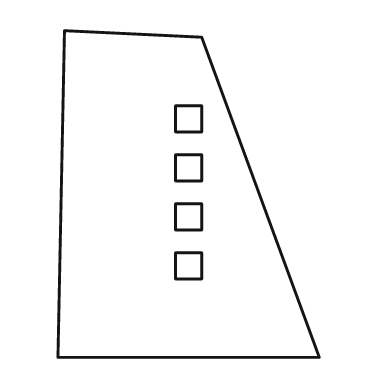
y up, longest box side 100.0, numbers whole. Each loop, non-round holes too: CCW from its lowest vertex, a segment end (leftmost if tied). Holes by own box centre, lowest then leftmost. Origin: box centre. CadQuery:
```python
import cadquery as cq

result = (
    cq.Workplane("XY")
    .moveTo(-40.0, -50.0)
    .lineTo(40.0, -50.0)
    .lineTo(4.0, 48.0)
    .lineTo(-38.0, 50.0)
    .close()
    .moveTo(-4.0, -26.0)
    .lineTo(4.0, -26.0)
    .lineTo(4.0, -18.0)
    .lineTo(-4.0, -18.0)
    .close()
    .moveTo(-4.0, -11.0)
    .lineTo(4.0, -11.0)
    .lineTo(4.0, -3.0)
    .lineTo(-4.0, -3.0)
    .close()
    .moveTo(-4.0, 4.0)
    .lineTo(4.0, 4.0)
    .lineTo(4.0, 12.0)
    .lineTo(-4.0, 12.0)
    .close()
    .moveTo(-4.0, 19.0)
    .lineTo(4.0, 19.0)
    .lineTo(4.0, 27.0)
    .lineTo(-4.0, 27.0)
    .close()
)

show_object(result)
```